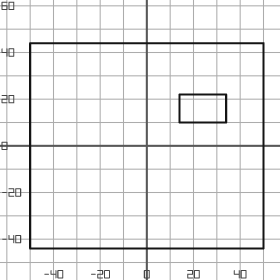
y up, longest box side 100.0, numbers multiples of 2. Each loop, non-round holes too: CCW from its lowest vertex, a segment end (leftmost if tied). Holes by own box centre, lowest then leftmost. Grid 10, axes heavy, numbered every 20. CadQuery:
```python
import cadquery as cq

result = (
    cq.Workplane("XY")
    .moveTo(-50.0, -44.0)
    .lineTo(50.0, -44.0)
    .lineTo(50.0, 44.0)
    .lineTo(-50.0, 44.0)
    .close()
    .moveTo(14.0, 10.0)
    .lineTo(34.0, 10.0)
    .lineTo(34.0, 22.0)
    .lineTo(14.0, 22.0)
    .close()
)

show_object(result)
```